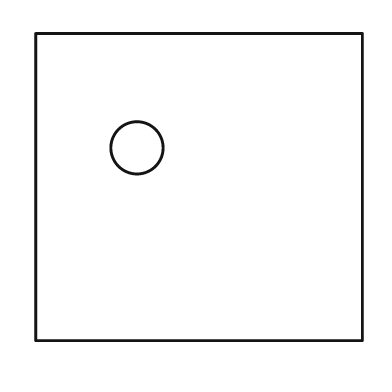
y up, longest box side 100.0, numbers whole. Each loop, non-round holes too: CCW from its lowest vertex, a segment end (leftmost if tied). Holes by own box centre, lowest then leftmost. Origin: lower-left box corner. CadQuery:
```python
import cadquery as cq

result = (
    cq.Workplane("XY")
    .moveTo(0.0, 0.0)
    .lineTo(100.0, 0.0)
    .lineTo(100.0, 94.0)
    .lineTo(0.0, 94.0)
    .close()
    .moveTo(31.0, 59.0)
    .circle(8.0)
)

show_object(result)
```